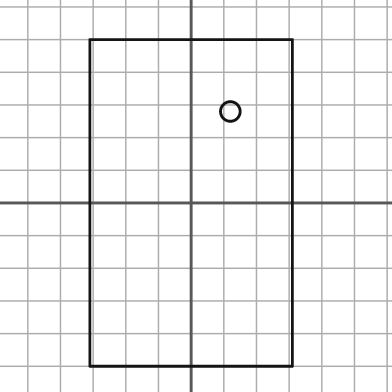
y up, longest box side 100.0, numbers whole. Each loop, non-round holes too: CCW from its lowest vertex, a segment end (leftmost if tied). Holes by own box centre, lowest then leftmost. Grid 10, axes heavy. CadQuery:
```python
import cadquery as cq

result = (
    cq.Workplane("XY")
    .moveTo(-31.0, -50.0)
    .lineTo(31.0, -50.0)
    .lineTo(31.0, 50.0)
    .lineTo(-31.0, 50.0)
    .close()
    .moveTo(12.0, 28.0)
    .circle(3.0)
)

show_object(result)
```